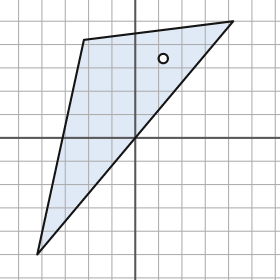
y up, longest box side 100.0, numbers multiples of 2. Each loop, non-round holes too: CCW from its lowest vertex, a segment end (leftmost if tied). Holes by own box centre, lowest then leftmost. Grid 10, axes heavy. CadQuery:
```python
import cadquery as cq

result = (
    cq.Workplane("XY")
    .moveTo(-42.0, -50.0)
    .lineTo(42.0, 50.0)
    .lineTo(-22.0, 42.0)
    .close()
    .moveTo(12.0, 34.0)
    .circle(2.0)
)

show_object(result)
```